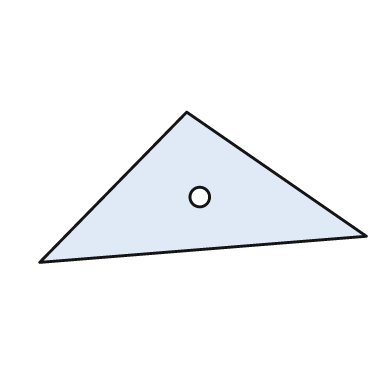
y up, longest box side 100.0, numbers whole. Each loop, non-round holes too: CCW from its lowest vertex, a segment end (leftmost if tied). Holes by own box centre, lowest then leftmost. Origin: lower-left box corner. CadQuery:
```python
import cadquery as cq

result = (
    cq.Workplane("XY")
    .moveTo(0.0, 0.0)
    .lineTo(100.0, 8.0)
    .lineTo(45.0, 46.0)
    .close()
    .moveTo(49.0, 20.0)
    .circle(3.0)
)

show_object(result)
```